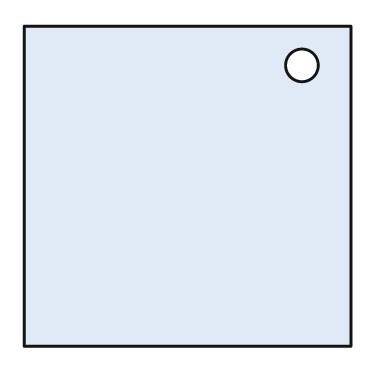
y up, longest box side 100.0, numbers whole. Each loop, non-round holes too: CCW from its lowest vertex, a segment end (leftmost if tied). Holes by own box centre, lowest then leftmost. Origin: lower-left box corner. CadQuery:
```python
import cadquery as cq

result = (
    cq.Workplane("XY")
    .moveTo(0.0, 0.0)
    .lineTo(100.0, 0.0)
    .lineTo(100.0, 98.0)
    .lineTo(0.0, 98.0)
    .close()
    .moveTo(85.0, 86.0)
    .circle(5.0)
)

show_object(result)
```